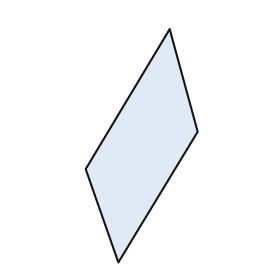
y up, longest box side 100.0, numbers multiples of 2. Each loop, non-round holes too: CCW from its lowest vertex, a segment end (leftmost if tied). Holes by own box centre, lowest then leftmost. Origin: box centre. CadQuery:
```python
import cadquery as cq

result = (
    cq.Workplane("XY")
    .moveTo(-10.0, -50.0)
    .lineTo(24.0, 6.0)
    .lineTo(12.0, 50.0)
    .lineTo(-24.0, -10.0)
    .close()
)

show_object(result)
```